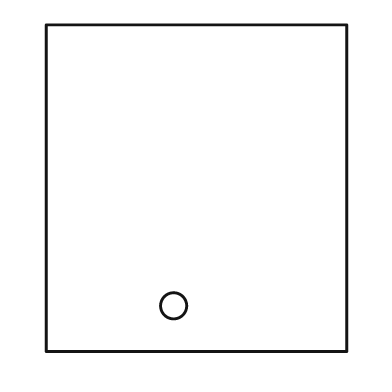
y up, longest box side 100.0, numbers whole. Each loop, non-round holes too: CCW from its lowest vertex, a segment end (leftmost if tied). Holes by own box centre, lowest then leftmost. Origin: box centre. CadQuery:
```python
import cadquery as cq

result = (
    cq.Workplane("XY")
    .moveTo(-46.0, -50.0)
    .lineTo(46.0, -50.0)
    .lineTo(46.0, 50.0)
    .lineTo(-46.0, 50.0)
    .close()
    .moveTo(-7.0, -36.0)
    .circle(4.0)
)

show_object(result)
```